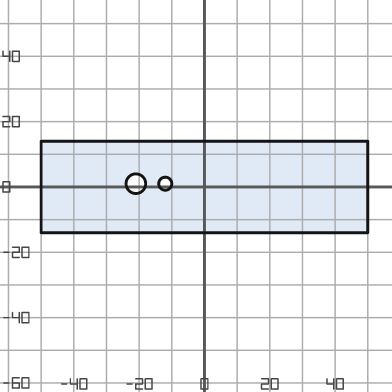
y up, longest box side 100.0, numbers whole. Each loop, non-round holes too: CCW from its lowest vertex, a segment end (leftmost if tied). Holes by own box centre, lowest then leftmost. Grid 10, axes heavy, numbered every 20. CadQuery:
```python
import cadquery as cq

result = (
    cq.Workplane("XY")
    .moveTo(-50.0, -14.0)
    .lineTo(50.0, -14.0)
    .lineTo(50.0, 14.0)
    .lineTo(-50.0, 14.0)
    .close()
    .moveTo(-21.0, 1.0)
    .circle(3.0)
    .moveTo(-12.0, 1.0)
    .circle(2.0)
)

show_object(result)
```